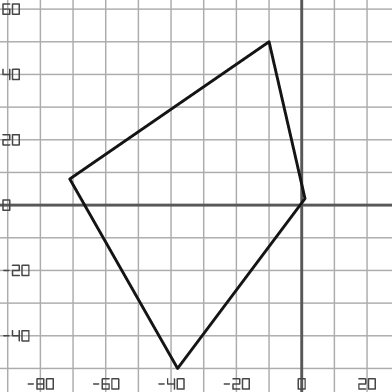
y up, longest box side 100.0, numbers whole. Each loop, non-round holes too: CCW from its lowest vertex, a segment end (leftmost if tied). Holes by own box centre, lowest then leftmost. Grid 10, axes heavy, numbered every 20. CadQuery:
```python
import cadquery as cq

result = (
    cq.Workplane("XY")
    .moveTo(-38.0, -50.0)
    .lineTo(1.0, 2.0)
    .lineTo(-10.0, 50.0)
    .lineTo(-71.0, 8.0)
    .close()
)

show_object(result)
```